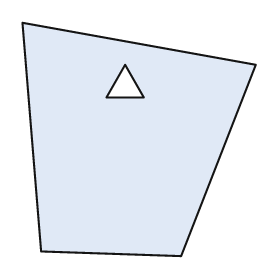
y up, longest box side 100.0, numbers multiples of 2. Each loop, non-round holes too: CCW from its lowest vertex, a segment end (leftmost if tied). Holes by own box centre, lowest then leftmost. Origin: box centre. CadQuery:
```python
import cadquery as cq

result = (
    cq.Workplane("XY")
    .moveTo(18.0, -50.0)
    .lineTo(50.0, 32.0)
    .lineTo(-50.0, 50.0)
    .lineTo(-42.0, -48.0)
    .close()
    .moveTo(-14.0, 18.0)
    .lineTo(2.0, 18.0)
    .lineTo(-6.0, 32.0)
    .close()
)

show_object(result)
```